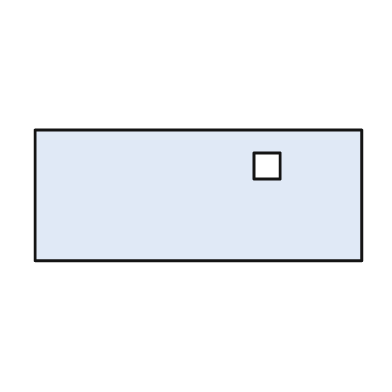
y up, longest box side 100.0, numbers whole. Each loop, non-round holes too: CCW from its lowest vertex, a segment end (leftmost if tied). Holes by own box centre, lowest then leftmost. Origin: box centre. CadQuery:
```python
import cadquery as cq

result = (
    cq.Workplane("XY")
    .moveTo(-50.0, -20.0)
    .lineTo(50.0, -20.0)
    .lineTo(50.0, 20.0)
    .lineTo(-50.0, 20.0)
    .close()
    .moveTo(17.0, 5.0)
    .lineTo(25.0, 5.0)
    .lineTo(25.0, 13.0)
    .lineTo(17.0, 13.0)
    .close()
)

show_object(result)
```